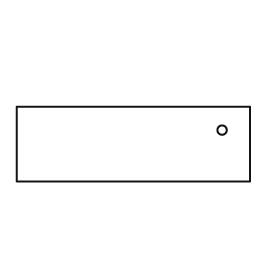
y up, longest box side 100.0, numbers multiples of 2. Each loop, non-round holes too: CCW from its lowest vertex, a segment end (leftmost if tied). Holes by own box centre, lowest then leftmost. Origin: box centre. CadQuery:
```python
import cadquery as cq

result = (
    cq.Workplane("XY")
    .moveTo(-50.0, -16.0)
    .lineTo(50.0, -16.0)
    .lineTo(50.0, 16.0)
    .lineTo(-50.0, 16.0)
    .close()
    .moveTo(38.0, 6.0)
    .circle(2.0)
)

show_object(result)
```